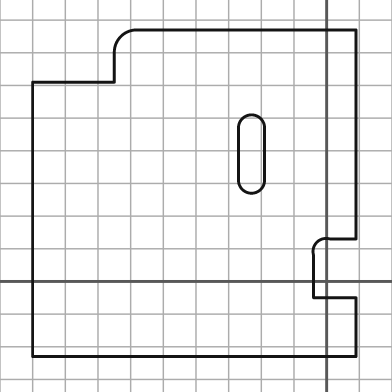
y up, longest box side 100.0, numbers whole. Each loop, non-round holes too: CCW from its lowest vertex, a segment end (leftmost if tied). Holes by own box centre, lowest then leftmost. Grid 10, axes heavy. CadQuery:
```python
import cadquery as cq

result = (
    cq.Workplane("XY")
    .moveTo(-90.0, -23.0)
    .lineTo(9.0, -23.0)
    .lineTo(9.0, -5.0)
    .lineTo(-4.0, -5.0)
    .lineTo(-4.0, 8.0)
    .threePointArc((-3.0, 12.0), (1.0, 13.0))
    .lineTo(9.0, 13.0)
    .lineTo(9.0, 77.0)
    .lineTo(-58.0, 77.0)
    .threePointArc((-63.0, 75.0), (-65.0, 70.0))
    .lineTo(-65.0, 61.0)
    .lineTo(-90.0, 61.0)
    .close()
    .moveTo(-27.0, 31.0)
    .threePointArc((-23.0, 27.0), (-19.0, 31.0))
    .lineTo(-19.0, 47.0)
    .threePointArc((-23.0, 51.0), (-27.0, 47.0))
    .close()
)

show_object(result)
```